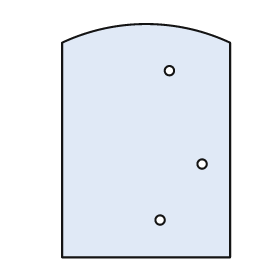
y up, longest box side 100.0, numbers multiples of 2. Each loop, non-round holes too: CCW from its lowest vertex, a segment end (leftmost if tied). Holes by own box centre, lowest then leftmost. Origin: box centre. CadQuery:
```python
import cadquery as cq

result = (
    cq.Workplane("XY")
    .moveTo(-36.0, -50.0)
    .lineTo(36.0, -50.0)
    .lineTo(36.0, 42.0)
    .threePointArc((0.0, 50.0), (-36.0, 42.0))
    .close()
    .moveTo(6.0, -34.0)
    .circle(2.0)
    .moveTo(24.0, -10.0)
    .circle(2.0)
    .moveTo(10.0, 30.0)
    .circle(2.0)
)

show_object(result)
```